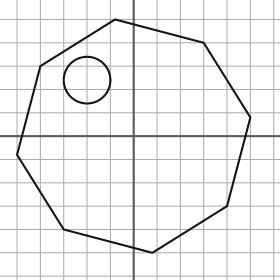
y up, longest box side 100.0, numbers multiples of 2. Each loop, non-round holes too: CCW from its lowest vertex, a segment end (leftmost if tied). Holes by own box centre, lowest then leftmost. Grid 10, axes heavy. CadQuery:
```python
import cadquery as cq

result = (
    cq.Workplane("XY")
    .moveTo(8.0, -50.0)
    .lineTo(40.0, -30.0)
    .lineTo(50.0, 8.0)
    .lineTo(30.0, 40.0)
    .lineTo(-8.0, 50.0)
    .lineTo(-40.0, 30.0)
    .lineTo(-50.0, -8.0)
    .lineTo(-30.0, -40.0)
    .close()
    .moveTo(-20.0, 24.0)
    .circle(10.0)
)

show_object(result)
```